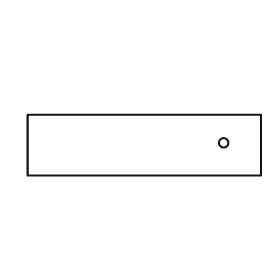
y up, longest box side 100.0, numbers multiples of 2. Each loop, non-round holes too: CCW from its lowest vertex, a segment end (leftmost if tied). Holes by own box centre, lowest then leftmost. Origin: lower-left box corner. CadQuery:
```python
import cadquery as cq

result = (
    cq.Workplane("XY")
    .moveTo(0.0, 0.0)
    .lineTo(100.0, 0.0)
    .lineTo(100.0, 26.0)
    .lineTo(0.0, 26.0)
    .close()
    .moveTo(84.0, 14.0)
    .circle(2.0)
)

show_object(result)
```